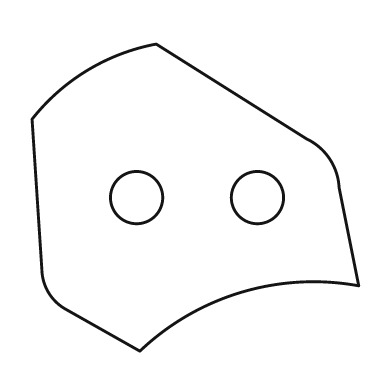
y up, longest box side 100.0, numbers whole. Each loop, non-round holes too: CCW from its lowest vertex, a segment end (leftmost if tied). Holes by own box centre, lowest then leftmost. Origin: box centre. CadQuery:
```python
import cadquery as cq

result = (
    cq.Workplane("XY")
    .moveTo(-17.0, -47.0)
    .threePointArc((14.0, -29.0), (50.0, -27.0))
    .lineTo(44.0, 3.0)
    .threePointArc((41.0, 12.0), (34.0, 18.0))
    .lineTo(-12.0, 47.0)
    .threePointArc((-33.0, 39.0), (-50.0, 24.0))
    .lineTo(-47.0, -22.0)
    .threePointArc((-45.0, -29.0), (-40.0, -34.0))
    .close()
    .moveTo(-18.0, 0.0)
    .circle(8.0)
    .moveTo(19.0, 0.0)
    .circle(8.0)
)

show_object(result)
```